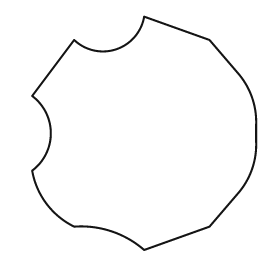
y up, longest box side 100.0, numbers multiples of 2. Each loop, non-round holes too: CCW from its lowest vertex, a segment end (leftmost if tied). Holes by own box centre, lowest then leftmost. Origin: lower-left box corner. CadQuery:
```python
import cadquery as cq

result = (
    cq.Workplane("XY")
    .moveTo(48.0, 0.0)
    .lineTo(76.0, 10.0)
    .lineTo(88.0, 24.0)
    .threePointArc((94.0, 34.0), (96.0, 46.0))
    .lineTo(96.0, 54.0)
    .threePointArc((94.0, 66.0), (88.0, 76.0))
    .lineTo(76.0, 90.0)
    .lineTo(48.0, 100.0)
    .threePointArc((36.0, 86.0), (18.0, 90.0))
    .lineTo(0.0, 66.0)
    .threePointArc((8.0, 50.0), (0.0, 34.0))
    .threePointArc((6.0, 20.0), (18.0, 10.0))
    .threePointArc((34.0, 8.0), (48.0, 0.0))
    .close()
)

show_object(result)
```